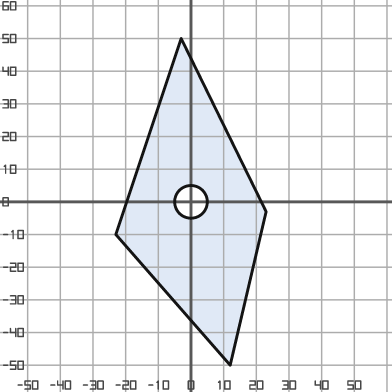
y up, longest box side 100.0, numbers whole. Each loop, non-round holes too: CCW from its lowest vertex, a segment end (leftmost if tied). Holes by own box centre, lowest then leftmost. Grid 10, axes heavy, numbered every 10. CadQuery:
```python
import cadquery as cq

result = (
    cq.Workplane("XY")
    .moveTo(12.0, -50.0)
    .lineTo(23.0, -3.0)
    .lineTo(-3.0, 50.0)
    .lineTo(-23.0, -10.0)
    .close()
    .moveTo(0.0, 0.0)
    .circle(5.0)
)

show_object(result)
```